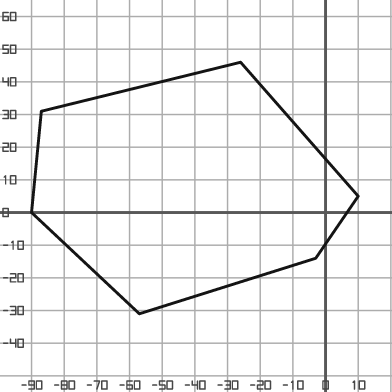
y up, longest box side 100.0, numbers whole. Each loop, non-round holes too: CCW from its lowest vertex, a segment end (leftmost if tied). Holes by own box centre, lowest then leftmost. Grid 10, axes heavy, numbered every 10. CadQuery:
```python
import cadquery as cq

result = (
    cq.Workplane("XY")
    .moveTo(-57.0, -31.0)
    .lineTo(-3.0, -14.0)
    .lineTo(10.0, 5.0)
    .lineTo(-26.0, 46.0)
    .lineTo(-87.0, 31.0)
    .lineTo(-90.0, 0.0)
    .close()
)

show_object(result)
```